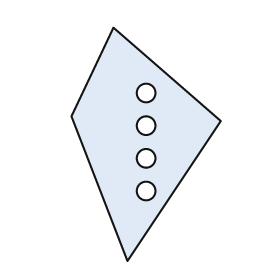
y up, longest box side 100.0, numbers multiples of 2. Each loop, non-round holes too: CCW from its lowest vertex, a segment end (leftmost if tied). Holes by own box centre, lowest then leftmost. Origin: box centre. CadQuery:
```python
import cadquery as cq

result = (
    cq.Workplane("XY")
    .moveTo(-8.0, -50.0)
    .lineTo(32.0, 10.0)
    .lineTo(-14.0, 50.0)
    .lineTo(-32.0, 12.0)
    .close()
    .moveTo(0.0, -20.0)
    .circle(4.0)
    .moveTo(0.0, -6.0)
    .circle(4.0)
    .moveTo(0.0, 8.0)
    .circle(4.0)
    .moveTo(0.0, 22.0)
    .circle(4.0)
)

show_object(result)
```